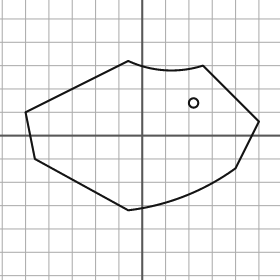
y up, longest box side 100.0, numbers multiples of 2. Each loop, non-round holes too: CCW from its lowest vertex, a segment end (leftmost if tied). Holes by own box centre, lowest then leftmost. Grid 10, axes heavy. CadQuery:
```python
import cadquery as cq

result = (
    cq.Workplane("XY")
    .moveTo(-6.0, -32.0)
    .threePointArc((18.0, -26.0), (40.0, -14.0))
    .lineTo(50.0, 6.0)
    .lineTo(26.0, 30.0)
    .threePointArc((10.0, 28.0), (-6.0, 32.0))
    .lineTo(-50.0, 10.0)
    .lineTo(-46.0, -10.0)
    .close()
    .moveTo(22.0, 14.0)
    .circle(2.0)
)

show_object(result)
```